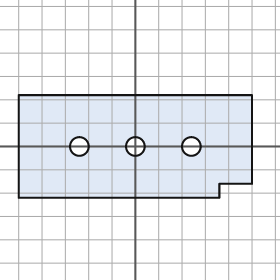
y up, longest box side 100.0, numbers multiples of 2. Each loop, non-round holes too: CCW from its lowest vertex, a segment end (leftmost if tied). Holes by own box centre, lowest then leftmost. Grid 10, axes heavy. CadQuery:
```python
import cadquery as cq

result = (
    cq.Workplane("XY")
    .moveTo(-50.0, -22.0)
    .lineTo(36.0, -22.0)
    .lineTo(36.0, -16.0)
    .lineTo(50.0, -16.0)
    .lineTo(50.0, 22.0)
    .lineTo(-50.0, 22.0)
    .close()
    .moveTo(-24.0, 0.0)
    .circle(4.0)
    .moveTo(0.0, 0.0)
    .circle(4.0)
    .moveTo(24.0, 0.0)
    .circle(4.0)
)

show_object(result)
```